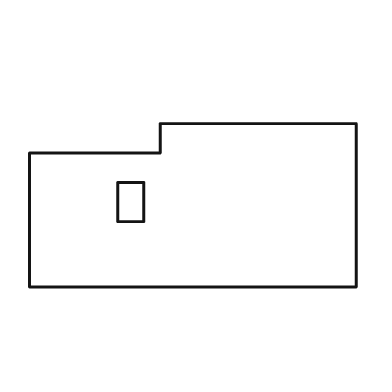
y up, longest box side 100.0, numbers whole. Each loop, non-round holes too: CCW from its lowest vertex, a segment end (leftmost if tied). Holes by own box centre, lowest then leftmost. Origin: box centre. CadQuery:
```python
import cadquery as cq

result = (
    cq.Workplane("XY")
    .moveTo(-50.0, -25.0)
    .lineTo(50.0, -25.0)
    .lineTo(50.0, 25.0)
    .lineTo(-10.0, 25.0)
    .lineTo(-10.0, 16.0)
    .lineTo(-50.0, 16.0)
    .close()
    .moveTo(-23.0, -5.0)
    .lineTo(-15.0, -5.0)
    .lineTo(-15.0, 7.0)
    .lineTo(-23.0, 7.0)
    .close()
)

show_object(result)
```